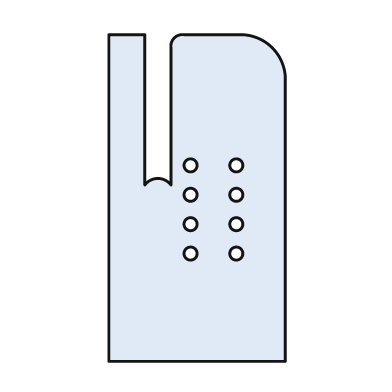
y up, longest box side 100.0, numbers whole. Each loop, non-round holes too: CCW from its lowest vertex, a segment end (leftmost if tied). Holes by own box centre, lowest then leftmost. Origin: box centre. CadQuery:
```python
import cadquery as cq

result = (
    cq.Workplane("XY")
    .moveTo(-27.0, -50.0)
    .lineTo(27.0, -50.0)
    .lineTo(27.0, 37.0)
    .threePointArc((23.0, 46.0), (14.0, 50.0))
    .lineTo(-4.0, 50.0)
    .threePointArc((-7.0, 49.0), (-8.0, 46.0))
    .lineTo(-8.0, 4.0)
    .threePointArc((-12.0, 6.0), (-16.0, 4.0))
    .lineTo(-16.0, 50.0)
    .lineTo(-27.0, 50.0)
    .close()
    .moveTo(-2.0, -17.0)
    .circle(2.0)
    .moveTo(12.0, -17.0)
    .circle(2.0)
    .moveTo(-2.0, -8.0)
    .circle(2.0)
    .moveTo(12.0, -8.0)
    .circle(2.0)
    .moveTo(-2.0, 1.0)
    .circle(2.0)
    .moveTo(12.0, 1.0)
    .circle(2.0)
    .moveTo(-2.0, 10.0)
    .circle(2.0)
    .moveTo(12.0, 10.0)
    .circle(2.0)
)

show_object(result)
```